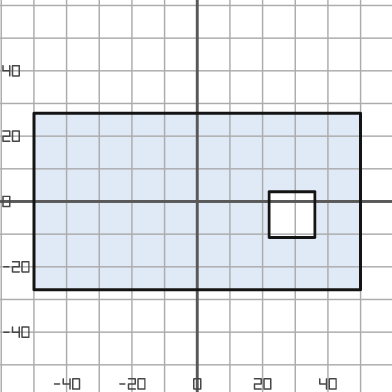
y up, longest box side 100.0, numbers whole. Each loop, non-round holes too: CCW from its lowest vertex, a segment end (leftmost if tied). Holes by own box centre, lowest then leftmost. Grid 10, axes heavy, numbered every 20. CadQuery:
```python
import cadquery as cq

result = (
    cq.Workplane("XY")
    .moveTo(-50.0, -27.0)
    .lineTo(50.0, -27.0)
    .lineTo(50.0, 27.0)
    .lineTo(-50.0, 27.0)
    .close()
    .moveTo(22.0, -11.0)
    .lineTo(36.0, -11.0)
    .lineTo(36.0, 3.0)
    .lineTo(22.0, 3.0)
    .close()
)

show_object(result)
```